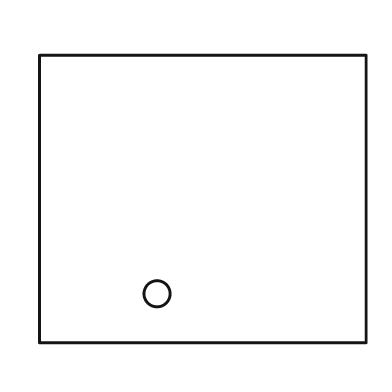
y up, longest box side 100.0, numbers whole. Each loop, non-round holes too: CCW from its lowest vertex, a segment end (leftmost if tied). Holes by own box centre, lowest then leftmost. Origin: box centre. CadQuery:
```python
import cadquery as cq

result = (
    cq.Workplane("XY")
    .moveTo(-50.0, -44.0)
    .lineTo(50.0, -44.0)
    .lineTo(50.0, 44.0)
    .lineTo(-50.0, 44.0)
    .close()
    .moveTo(-14.0, -29.0)
    .circle(4.0)
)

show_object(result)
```